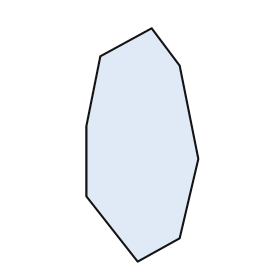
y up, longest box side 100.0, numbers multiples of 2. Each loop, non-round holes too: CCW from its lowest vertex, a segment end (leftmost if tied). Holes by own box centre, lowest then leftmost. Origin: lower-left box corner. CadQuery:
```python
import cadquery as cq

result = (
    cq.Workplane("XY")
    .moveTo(22.0, 0.0)
    .lineTo(40.0, 10.0)
    .lineTo(48.0, 44.0)
    .lineTo(40.0, 84.0)
    .lineTo(28.0, 100.0)
    .lineTo(6.0, 88.0)
    .lineTo(0.0, 58.0)
    .lineTo(0.0, 28.0)
    .close()
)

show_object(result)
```